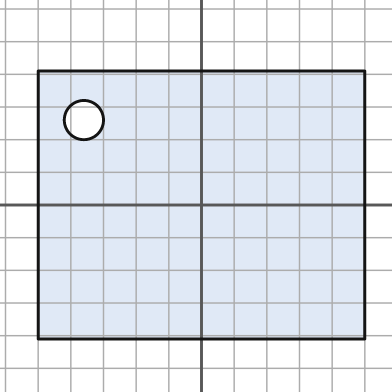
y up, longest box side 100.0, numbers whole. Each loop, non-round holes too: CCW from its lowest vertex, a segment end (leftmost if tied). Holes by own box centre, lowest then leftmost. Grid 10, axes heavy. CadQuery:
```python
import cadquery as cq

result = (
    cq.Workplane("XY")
    .moveTo(-50.0, -41.0)
    .lineTo(50.0, -41.0)
    .lineTo(50.0, 41.0)
    .lineTo(-50.0, 41.0)
    .close()
    .moveTo(-36.0, 26.0)
    .circle(6.0)
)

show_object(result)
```